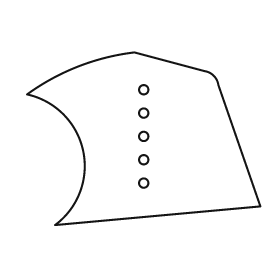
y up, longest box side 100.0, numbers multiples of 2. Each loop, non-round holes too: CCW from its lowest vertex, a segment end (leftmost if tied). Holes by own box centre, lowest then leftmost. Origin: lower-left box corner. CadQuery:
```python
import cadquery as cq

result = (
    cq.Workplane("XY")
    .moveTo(12.0, 0.0)
    .lineTo(100.0, 8.0)
    .lineTo(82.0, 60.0)
    .threePointArc((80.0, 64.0), (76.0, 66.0))
    .lineTo(46.0, 74.0)
    .threePointArc((22.0, 68.0), (0.0, 56.0))
    .threePointArc((24.0, 32.0), (12.0, 0.0))
    .close()
    .moveTo(50.0, 18.0)
    .circle(2.0)
    .moveTo(50.0, 28.0)
    .circle(2.0)
    .moveTo(50.0, 38.0)
    .circle(2.0)
    .moveTo(50.0, 48.0)
    .circle(2.0)
    .moveTo(50.0, 58.0)
    .circle(2.0)
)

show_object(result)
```